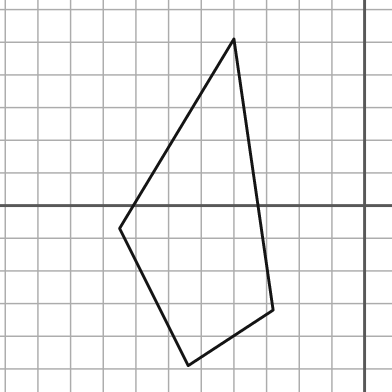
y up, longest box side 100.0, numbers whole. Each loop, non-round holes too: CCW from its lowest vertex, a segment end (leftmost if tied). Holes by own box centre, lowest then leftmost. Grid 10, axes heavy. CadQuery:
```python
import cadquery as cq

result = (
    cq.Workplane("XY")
    .moveTo(-54.0, -49.0)
    .lineTo(-28.0, -32.0)
    .lineTo(-40.0, 51.0)
    .lineTo(-75.0, -7.0)
    .close()
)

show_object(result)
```